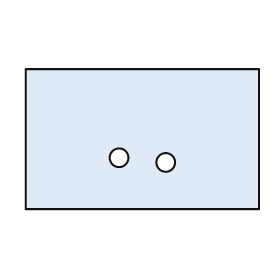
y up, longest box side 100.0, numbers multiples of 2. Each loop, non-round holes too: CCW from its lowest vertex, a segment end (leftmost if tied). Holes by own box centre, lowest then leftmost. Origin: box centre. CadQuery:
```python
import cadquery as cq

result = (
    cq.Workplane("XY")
    .moveTo(-50.0, -30.0)
    .lineTo(50.0, -30.0)
    .lineTo(50.0, 30.0)
    .lineTo(-50.0, 30.0)
    .close()
    .moveTo(10.0, -10.0)
    .circle(4.0)
    .moveTo(-10.0, -8.0)
    .circle(4.0)
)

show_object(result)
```